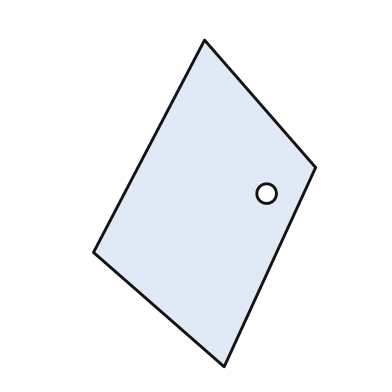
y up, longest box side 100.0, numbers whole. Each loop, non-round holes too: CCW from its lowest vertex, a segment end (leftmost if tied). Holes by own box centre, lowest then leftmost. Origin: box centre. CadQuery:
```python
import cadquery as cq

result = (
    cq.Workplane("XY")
    .moveTo(6.0, -50.0)
    .lineTo(34.0, 11.0)
    .lineTo(0.0, 50.0)
    .lineTo(-34.0, -15.0)
    .close()
    .moveTo(19.0, 3.0)
    .circle(3.0)
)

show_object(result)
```